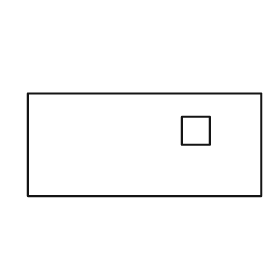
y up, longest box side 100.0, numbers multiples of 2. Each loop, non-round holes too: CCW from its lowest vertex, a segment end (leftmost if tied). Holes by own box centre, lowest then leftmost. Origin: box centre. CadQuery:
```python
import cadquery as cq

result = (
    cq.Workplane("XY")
    .moveTo(-50.0, -22.0)
    .lineTo(50.0, -22.0)
    .lineTo(50.0, 22.0)
    .lineTo(-50.0, 22.0)
    .close()
    .moveTo(16.0, 0.0)
    .lineTo(28.0, 0.0)
    .lineTo(28.0, 12.0)
    .lineTo(16.0, 12.0)
    .close()
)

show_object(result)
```